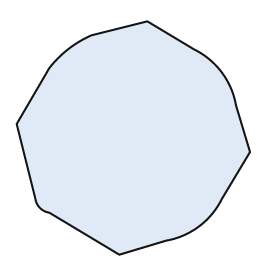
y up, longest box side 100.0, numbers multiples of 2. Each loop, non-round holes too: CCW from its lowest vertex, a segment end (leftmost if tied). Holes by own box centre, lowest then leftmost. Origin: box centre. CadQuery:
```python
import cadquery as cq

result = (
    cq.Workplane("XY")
    .moveTo(-6.0, -50.0)
    .lineTo(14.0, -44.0)
    .threePointArc((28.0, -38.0), (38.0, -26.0))
    .lineTo(50.0, -6.0)
    .lineTo(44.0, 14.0)
    .threePointArc((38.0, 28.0), (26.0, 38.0))
    .lineTo(6.0, 50.0)
    .lineTo(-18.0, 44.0)
    .threePointArc((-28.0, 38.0), (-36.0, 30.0))
    .lineTo(-50.0, 6.0)
    .lineTo(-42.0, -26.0)
    .threePointArc((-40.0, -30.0), (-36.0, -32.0))
    .close()
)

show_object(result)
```